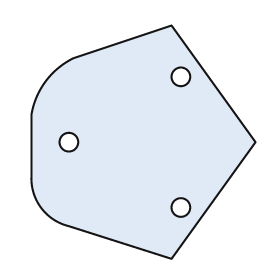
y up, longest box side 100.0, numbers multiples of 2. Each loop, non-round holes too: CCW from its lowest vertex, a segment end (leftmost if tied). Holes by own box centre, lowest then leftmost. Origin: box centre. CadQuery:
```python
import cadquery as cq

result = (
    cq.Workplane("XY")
    .moveTo(12.0, -50.0)
    .lineTo(48.0, 0.0)
    .lineTo(12.0, 50.0)
    .lineTo(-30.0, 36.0)
    .threePointArc((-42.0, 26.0), (-48.0, 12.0))
    .lineTo(-48.0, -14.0)
    .threePointArc((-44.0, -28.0), (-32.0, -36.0))
    .close()
    .moveTo(16.0, -28.0)
    .circle(4.0)
    .moveTo(-32.0, 0.0)
    .circle(4.0)
    .moveTo(16.0, 28.0)
    .circle(4.0)
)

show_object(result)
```